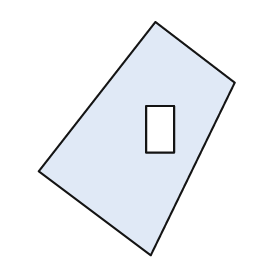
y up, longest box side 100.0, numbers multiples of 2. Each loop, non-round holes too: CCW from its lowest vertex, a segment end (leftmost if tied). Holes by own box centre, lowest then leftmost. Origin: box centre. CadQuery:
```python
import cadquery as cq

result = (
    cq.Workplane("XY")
    .moveTo(6.0, -50.0)
    .lineTo(42.0, 24.0)
    .lineTo(8.0, 50.0)
    .lineTo(-42.0, -14.0)
    .close()
    .moveTo(4.0, -6.0)
    .lineTo(16.0, -6.0)
    .lineTo(16.0, 14.0)
    .lineTo(4.0, 14.0)
    .close()
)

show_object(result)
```